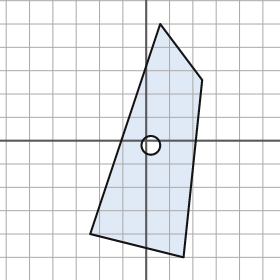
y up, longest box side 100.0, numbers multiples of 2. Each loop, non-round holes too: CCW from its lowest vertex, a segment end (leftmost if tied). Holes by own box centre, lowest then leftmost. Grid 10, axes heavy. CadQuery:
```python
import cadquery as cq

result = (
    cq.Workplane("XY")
    .moveTo(16.0, -50.0)
    .lineTo(24.0, 26.0)
    .lineTo(6.0, 50.0)
    .lineTo(-24.0, -40.0)
    .close()
    .moveTo(2.0, -2.0)
    .circle(4.0)
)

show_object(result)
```